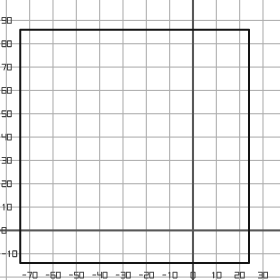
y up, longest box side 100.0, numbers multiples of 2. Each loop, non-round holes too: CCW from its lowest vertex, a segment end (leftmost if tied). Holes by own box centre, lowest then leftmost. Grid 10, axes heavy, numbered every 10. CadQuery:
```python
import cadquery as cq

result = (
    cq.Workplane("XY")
    .moveTo(-74.0, -14.0)
    .lineTo(24.0, -14.0)
    .lineTo(24.0, 86.0)
    .lineTo(-74.0, 86.0)
    .close()
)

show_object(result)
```